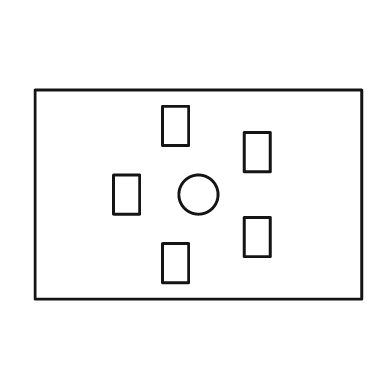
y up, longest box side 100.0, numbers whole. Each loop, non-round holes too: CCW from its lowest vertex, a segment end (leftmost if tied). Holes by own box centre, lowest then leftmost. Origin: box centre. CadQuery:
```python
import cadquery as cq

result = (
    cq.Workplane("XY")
    .moveTo(-50.0, -32.0)
    .lineTo(50.0, -32.0)
    .lineTo(50.0, 32.0)
    .lineTo(-50.0, 32.0)
    .close()
    .moveTo(-11.0, -27.0)
    .lineTo(-3.0, -27.0)
    .lineTo(-3.0, -15.0)
    .lineTo(-11.0, -15.0)
    .close()
    .moveTo(14.0, -19.0)
    .lineTo(22.0, -19.0)
    .lineTo(22.0, -7.0)
    .lineTo(14.0, -7.0)
    .close()
    .moveTo(-26.0, -6.0)
    .lineTo(-18.0, -6.0)
    .lineTo(-18.0, 6.0)
    .lineTo(-26.0, 6.0)
    .close()
    .moveTo(0.0, 0.0)
    .circle(6.0)
    .moveTo(14.0, 7.0)
    .lineTo(22.0, 7.0)
    .lineTo(22.0, 19.0)
    .lineTo(14.0, 19.0)
    .close()
    .moveTo(-11.0, 15.0)
    .lineTo(-3.0, 15.0)
    .lineTo(-3.0, 27.0)
    .lineTo(-11.0, 27.0)
    .close()
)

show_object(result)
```